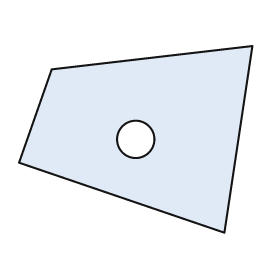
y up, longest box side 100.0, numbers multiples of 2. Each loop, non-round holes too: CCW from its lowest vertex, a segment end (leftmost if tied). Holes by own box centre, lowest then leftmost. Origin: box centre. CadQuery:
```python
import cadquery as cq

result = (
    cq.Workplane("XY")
    .moveTo(38.0, -40.0)
    .lineTo(50.0, 40.0)
    .lineTo(-36.0, 30.0)
    .lineTo(-50.0, -10.0)
    .close()
    .moveTo(0.0, 0.0)
    .circle(8.0)
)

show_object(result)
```